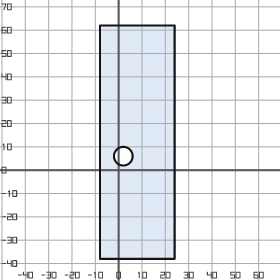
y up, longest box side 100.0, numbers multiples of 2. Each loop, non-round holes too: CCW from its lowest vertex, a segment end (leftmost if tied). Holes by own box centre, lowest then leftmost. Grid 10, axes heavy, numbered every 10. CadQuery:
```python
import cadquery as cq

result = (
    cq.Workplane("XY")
    .moveTo(-8.0, -38.0)
    .lineTo(24.0, -38.0)
    .lineTo(24.0, 62.0)
    .lineTo(-8.0, 62.0)
    .close()
    .moveTo(2.0, 6.0)
    .circle(4.0)
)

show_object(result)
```